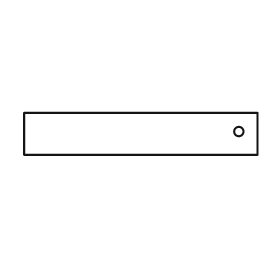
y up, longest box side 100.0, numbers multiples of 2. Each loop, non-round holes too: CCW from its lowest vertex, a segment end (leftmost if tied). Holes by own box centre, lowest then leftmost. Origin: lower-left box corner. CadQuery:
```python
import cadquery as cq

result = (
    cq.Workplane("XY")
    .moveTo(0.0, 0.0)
    .lineTo(100.0, 0.0)
    .lineTo(100.0, 18.0)
    .lineTo(0.0, 18.0)
    .close()
    .moveTo(92.0, 10.0)
    .circle(2.0)
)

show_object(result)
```